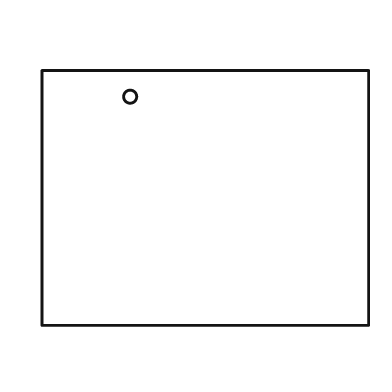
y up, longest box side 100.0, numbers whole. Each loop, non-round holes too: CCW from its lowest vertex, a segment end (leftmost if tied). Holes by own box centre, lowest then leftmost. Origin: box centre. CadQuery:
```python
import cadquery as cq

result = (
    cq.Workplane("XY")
    .moveTo(-50.0, -39.0)
    .lineTo(50.0, -39.0)
    .lineTo(50.0, 39.0)
    .lineTo(-50.0, 39.0)
    .close()
    .moveTo(-23.0, 31.0)
    .circle(2.0)
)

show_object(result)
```